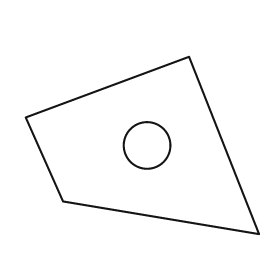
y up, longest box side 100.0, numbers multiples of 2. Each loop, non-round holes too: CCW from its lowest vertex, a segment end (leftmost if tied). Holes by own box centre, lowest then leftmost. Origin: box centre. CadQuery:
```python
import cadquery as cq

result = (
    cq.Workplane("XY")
    .moveTo(50.0, -38.0)
    .lineTo(20.0, 38.0)
    .lineTo(-50.0, 12.0)
    .lineTo(-34.0, -24.0)
    .close()
    .moveTo(2.0, 0.0)
    .circle(10.0)
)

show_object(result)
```